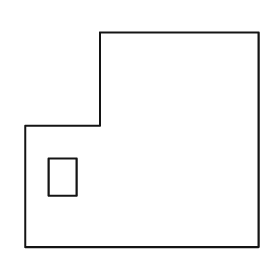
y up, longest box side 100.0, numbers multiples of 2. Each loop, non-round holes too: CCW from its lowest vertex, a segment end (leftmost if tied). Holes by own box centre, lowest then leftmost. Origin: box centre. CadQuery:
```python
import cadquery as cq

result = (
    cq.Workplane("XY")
    .moveTo(-50.0, -46.0)
    .lineTo(50.0, -46.0)
    .lineTo(50.0, 46.0)
    .lineTo(-18.0, 46.0)
    .lineTo(-18.0, 6.0)
    .lineTo(-50.0, 6.0)
    .close()
    .moveTo(-40.0, -24.0)
    .lineTo(-28.0, -24.0)
    .lineTo(-28.0, -8.0)
    .lineTo(-40.0, -8.0)
    .close()
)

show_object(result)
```